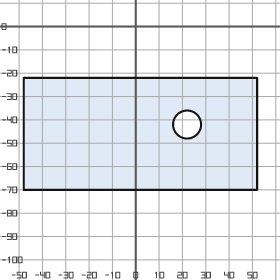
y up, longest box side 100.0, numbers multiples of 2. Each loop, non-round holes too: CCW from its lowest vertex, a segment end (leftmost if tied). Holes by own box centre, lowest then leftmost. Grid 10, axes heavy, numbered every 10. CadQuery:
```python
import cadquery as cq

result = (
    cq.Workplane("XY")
    .moveTo(-48.0, -70.0)
    .lineTo(52.0, -70.0)
    .lineTo(52.0, -22.0)
    .lineTo(-48.0, -22.0)
    .close()
    .moveTo(22.0, -42.0)
    .circle(6.0)
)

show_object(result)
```